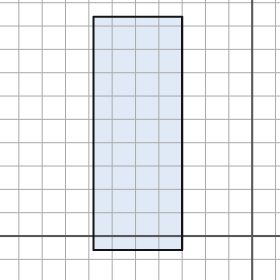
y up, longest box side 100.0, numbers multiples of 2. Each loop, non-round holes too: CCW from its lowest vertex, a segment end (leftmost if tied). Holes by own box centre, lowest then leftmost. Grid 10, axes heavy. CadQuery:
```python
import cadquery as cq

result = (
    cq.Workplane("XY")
    .moveTo(-68.0, -6.0)
    .lineTo(-30.0, -6.0)
    .lineTo(-30.0, 94.0)
    .lineTo(-68.0, 94.0)
    .close()
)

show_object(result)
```